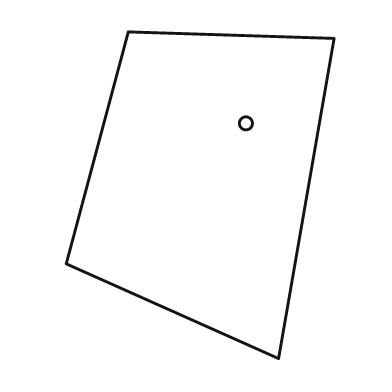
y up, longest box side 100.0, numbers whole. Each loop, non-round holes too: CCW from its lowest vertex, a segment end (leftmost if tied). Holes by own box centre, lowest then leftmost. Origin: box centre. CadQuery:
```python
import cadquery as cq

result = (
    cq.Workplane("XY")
    .moveTo(24.0, -50.0)
    .lineTo(41.0, 48.0)
    .lineTo(-22.0, 50.0)
    .lineTo(-41.0, -21.0)
    .close()
    .moveTo(14.0, 22.0)
    .circle(2.0)
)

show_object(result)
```